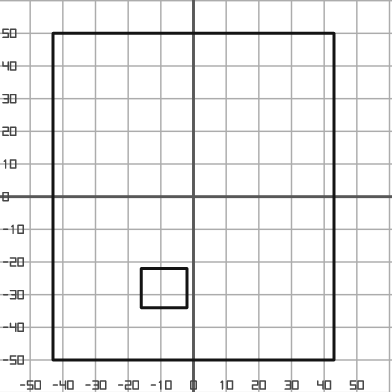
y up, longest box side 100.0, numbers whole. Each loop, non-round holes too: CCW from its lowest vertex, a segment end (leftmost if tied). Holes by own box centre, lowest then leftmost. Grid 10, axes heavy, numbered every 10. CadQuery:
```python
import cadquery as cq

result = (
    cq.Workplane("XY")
    .moveTo(-43.0, -50.0)
    .lineTo(43.0, -50.0)
    .lineTo(43.0, 50.0)
    .lineTo(-43.0, 50.0)
    .close()
    .moveTo(-16.0, -34.0)
    .lineTo(-2.0, -34.0)
    .lineTo(-2.0, -22.0)
    .lineTo(-16.0, -22.0)
    .close()
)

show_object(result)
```